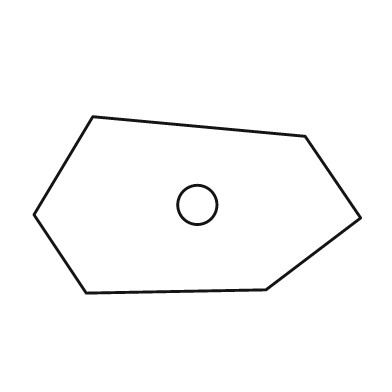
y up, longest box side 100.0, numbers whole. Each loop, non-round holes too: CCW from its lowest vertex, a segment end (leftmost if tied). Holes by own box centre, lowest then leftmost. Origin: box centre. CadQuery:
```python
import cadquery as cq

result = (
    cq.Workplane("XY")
    .moveTo(-34.0, -27.0)
    .lineTo(21.0, -26.0)
    .lineTo(50.0, -4.0)
    .lineTo(33.0, 21.0)
    .lineTo(-32.0, 27.0)
    .lineTo(-50.0, -3.0)
    .close()
    .moveTo(0.0, 0.0)
    .circle(6.0)
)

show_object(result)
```